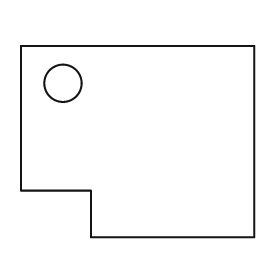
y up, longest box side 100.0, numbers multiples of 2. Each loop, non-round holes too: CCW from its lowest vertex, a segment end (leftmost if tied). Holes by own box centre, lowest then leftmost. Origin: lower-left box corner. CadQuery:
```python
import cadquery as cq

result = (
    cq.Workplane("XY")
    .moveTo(30.0, 0.0)
    .lineTo(100.0, 0.0)
    .lineTo(100.0, 82.0)
    .lineTo(0.0, 82.0)
    .lineTo(0.0, 20.0)
    .lineTo(30.0, 20.0)
    .close()
    .moveTo(18.0, 66.0)
    .circle(8.0)
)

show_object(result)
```